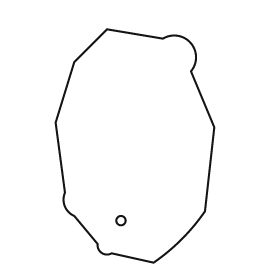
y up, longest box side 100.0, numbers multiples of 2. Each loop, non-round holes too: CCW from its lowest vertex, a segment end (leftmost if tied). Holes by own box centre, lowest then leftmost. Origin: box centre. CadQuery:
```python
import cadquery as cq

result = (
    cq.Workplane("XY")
    .moveTo(8.0, -50.0)
    .threePointArc((20.0, -40.0), (30.0, -28.0))
    .lineTo(34.0, 8.0)
    .lineTo(24.0, 32.0)
    .threePointArc((24.0, 44.0), (12.0, 46.0))
    .lineTo(-12.0, 50.0)
    .lineTo(-26.0, 36.0)
    .lineTo(-34.0, 10.0)
    .lineTo(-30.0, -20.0)
    .threePointArc((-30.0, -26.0), (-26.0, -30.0))
    .lineTo(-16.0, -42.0)
    .threePointArc((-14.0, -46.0), (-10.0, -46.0))
    .close()
    .moveTo(-6.0, -32.0)
    .circle(2.0)
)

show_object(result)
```